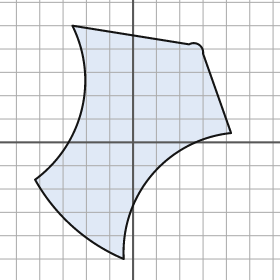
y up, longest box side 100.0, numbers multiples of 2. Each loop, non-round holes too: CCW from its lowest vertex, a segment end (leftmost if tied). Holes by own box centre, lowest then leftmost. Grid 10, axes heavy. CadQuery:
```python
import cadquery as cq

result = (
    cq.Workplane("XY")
    .moveTo(-4.0, -50.0)
    .threePointArc((8.0, -14.0), (42.0, 4.0))
    .lineTo(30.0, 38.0)
    .threePointArc((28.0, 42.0), (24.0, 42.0))
    .lineTo(-26.0, 50.0)
    .threePointArc((-22.0, 14.0), (-42.0, -16.0))
    .threePointArc((-26.0, -36.0), (-4.0, -50.0))
    .close()
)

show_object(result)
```